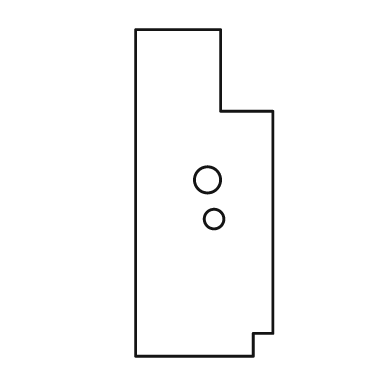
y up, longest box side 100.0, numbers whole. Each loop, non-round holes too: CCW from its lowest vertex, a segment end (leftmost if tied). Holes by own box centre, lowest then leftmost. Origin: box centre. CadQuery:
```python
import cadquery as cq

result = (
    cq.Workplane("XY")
    .moveTo(-21.0, -50.0)
    .lineTo(15.0, -50.0)
    .lineTo(15.0, -43.0)
    .lineTo(21.0, -43.0)
    .lineTo(21.0, 25.0)
    .lineTo(5.0, 25.0)
    .lineTo(5.0, 50.0)
    .lineTo(-21.0, 50.0)
    .close()
    .moveTo(3.0, -8.0)
    .circle(3.0)
    .moveTo(1.0, 4.0)
    .circle(4.0)
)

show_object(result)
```